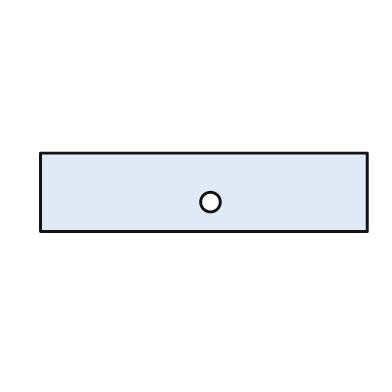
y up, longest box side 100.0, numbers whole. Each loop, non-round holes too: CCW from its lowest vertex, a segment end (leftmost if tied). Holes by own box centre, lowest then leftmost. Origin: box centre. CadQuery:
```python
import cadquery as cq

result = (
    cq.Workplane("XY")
    .moveTo(-50.0, -12.0)
    .lineTo(50.0, -12.0)
    .lineTo(50.0, 12.0)
    .lineTo(-50.0, 12.0)
    .close()
    .moveTo(2.0, -3.0)
    .circle(3.0)
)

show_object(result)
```